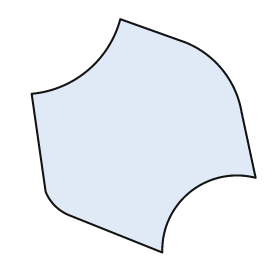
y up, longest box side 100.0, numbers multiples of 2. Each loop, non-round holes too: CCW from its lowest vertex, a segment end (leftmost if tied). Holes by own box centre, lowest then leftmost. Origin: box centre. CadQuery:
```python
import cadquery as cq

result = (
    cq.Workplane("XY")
    .moveTo(8.0, -50.0)
    .threePointArc((20.0, -24.0), (48.0, -18.0))
    .lineTo(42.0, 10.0)
    .threePointArc((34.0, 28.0), (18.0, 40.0))
    .lineTo(-10.0, 50.0)
    .threePointArc((-24.0, 28.0), (-48.0, 18.0))
    .lineTo(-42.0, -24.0)
    .threePointArc((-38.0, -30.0), (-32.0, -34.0))
    .close()
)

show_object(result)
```